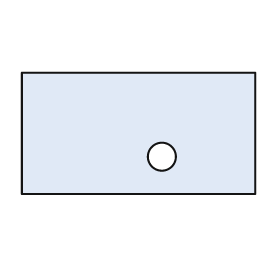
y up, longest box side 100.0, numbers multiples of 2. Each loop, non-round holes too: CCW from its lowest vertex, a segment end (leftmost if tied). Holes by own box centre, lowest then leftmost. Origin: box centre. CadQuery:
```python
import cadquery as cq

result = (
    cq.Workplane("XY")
    .moveTo(-50.0, -26.0)
    .lineTo(50.0, -26.0)
    .lineTo(50.0, 26.0)
    .lineTo(-50.0, 26.0)
    .close()
    .moveTo(10.0, -10.0)
    .circle(6.0)
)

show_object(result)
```